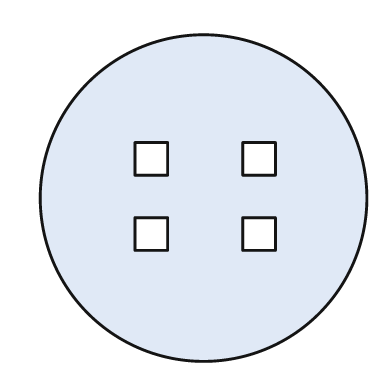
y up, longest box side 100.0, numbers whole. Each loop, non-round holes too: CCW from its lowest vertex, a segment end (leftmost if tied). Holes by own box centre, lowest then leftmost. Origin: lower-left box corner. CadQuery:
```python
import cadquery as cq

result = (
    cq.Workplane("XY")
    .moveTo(50.0, 50.0)
    .circle(50.0)
    .moveTo(29.0, 34.0)
    .lineTo(39.0, 34.0)
    .lineTo(39.0, 44.0)
    .lineTo(29.0, 44.0)
    .close()
    .moveTo(62.0, 34.0)
    .lineTo(72.0, 34.0)
    .lineTo(72.0, 44.0)
    .lineTo(62.0, 44.0)
    .close()
    .moveTo(29.0, 57.0)
    .lineTo(39.0, 57.0)
    .lineTo(39.0, 67.0)
    .lineTo(29.0, 67.0)
    .close()
    .moveTo(62.0, 57.0)
    .lineTo(72.0, 57.0)
    .lineTo(72.0, 67.0)
    .lineTo(62.0, 67.0)
    .close()
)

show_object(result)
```